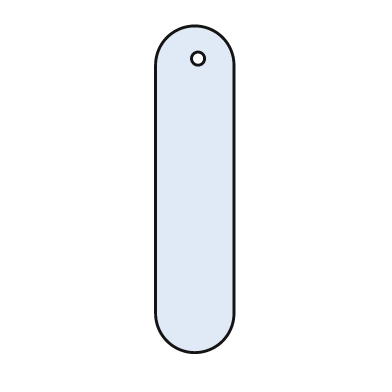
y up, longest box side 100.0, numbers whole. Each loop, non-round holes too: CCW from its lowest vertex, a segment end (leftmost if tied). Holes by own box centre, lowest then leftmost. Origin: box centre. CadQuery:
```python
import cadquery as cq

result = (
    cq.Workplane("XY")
    .moveTo(-12.0, -38.0)
    .threePointArc((0.0, -50.0), (12.0, -38.0))
    .lineTo(12.0, 38.0)
    .threePointArc((0.0, 50.0), (-12.0, 38.0))
    .close()
    .moveTo(1.0, 40.0)
    .circle(2.0)
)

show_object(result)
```